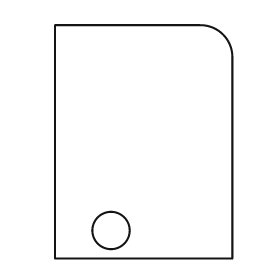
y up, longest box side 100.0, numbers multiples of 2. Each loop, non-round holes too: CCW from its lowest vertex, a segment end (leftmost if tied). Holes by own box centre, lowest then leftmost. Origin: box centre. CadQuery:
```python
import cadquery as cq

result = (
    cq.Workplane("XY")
    .moveTo(-38.0, -50.0)
    .lineTo(38.0, -50.0)
    .lineTo(38.0, 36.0)
    .threePointArc((34.0, 46.0), (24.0, 50.0))
    .lineTo(-38.0, 50.0)
    .close()
    .moveTo(-14.0, -38.0)
    .circle(8.0)
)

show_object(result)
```